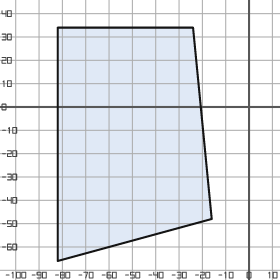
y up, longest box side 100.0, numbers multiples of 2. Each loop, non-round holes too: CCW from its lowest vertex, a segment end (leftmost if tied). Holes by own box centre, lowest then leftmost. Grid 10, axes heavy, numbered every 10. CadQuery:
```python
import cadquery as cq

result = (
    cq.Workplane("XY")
    .moveTo(-82.0, -66.0)
    .lineTo(-16.0, -48.0)
    .lineTo(-24.0, 34.0)
    .lineTo(-82.0, 34.0)
    .close()
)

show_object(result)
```